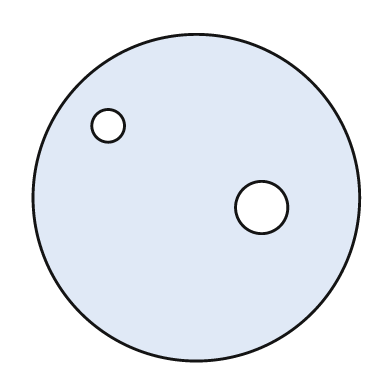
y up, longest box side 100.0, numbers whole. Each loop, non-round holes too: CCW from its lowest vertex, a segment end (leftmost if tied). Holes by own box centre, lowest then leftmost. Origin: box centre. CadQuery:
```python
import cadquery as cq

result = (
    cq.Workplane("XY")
    .moveTo(0.0, 0.0)
    .circle(50.0)
    .moveTo(20.0, -3.0)
    .circle(8.0)
    .moveTo(-27.0, 22.0)
    .circle(5.0)
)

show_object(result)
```